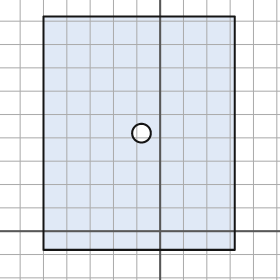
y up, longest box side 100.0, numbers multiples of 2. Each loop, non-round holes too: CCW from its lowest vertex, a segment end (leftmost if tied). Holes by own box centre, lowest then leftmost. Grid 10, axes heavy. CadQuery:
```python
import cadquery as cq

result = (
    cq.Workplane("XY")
    .moveTo(-50.0, -8.0)
    .lineTo(32.0, -8.0)
    .lineTo(32.0, 92.0)
    .lineTo(-50.0, 92.0)
    .close()
    .moveTo(-8.0, 42.0)
    .circle(4.0)
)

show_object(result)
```